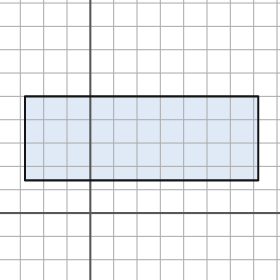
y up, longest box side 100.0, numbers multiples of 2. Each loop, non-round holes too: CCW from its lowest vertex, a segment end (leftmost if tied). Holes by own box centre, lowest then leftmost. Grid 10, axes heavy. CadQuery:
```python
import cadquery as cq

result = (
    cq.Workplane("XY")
    .moveTo(-28.0, 14.0)
    .lineTo(72.0, 14.0)
    .lineTo(72.0, 50.0)
    .lineTo(-28.0, 50.0)
    .close()
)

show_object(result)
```